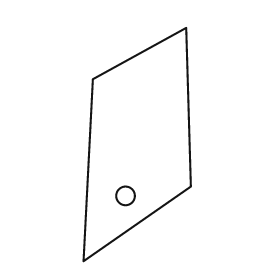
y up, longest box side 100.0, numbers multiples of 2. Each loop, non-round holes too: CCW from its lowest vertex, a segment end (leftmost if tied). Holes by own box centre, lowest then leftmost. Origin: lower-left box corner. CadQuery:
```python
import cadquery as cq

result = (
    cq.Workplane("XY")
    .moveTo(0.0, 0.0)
    .lineTo(46.0, 32.0)
    .lineTo(44.0, 100.0)
    .lineTo(4.0, 78.0)
    .close()
    .moveTo(18.0, 28.0)
    .circle(4.0)
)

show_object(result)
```